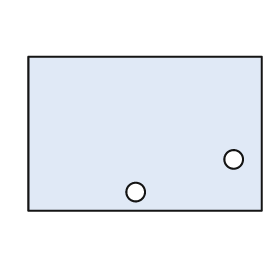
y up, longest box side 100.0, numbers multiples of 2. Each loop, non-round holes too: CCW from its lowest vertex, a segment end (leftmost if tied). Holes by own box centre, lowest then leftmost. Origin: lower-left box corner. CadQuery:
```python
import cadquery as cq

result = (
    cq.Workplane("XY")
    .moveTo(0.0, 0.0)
    .lineTo(100.0, 0.0)
    .lineTo(100.0, 66.0)
    .lineTo(0.0, 66.0)
    .close()
    .moveTo(46.0, 8.0)
    .circle(4.0)
    .moveTo(88.0, 22.0)
    .circle(4.0)
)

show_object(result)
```